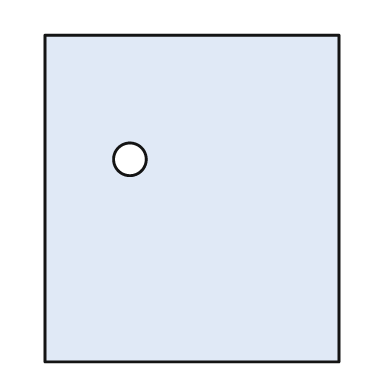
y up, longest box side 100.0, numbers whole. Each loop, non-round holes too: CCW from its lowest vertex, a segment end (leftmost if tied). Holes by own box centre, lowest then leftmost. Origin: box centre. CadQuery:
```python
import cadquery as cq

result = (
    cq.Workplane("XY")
    .moveTo(-45.0, -50.0)
    .lineTo(45.0, -50.0)
    .lineTo(45.0, 50.0)
    .lineTo(-45.0, 50.0)
    .close()
    .moveTo(-19.0, 12.0)
    .circle(5.0)
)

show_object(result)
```